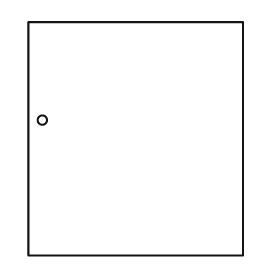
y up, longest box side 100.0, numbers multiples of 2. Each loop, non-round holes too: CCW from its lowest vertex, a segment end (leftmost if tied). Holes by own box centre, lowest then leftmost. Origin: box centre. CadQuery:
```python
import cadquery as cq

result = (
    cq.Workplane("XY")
    .moveTo(-46.0, -50.0)
    .lineTo(46.0, -50.0)
    .lineTo(46.0, 50.0)
    .lineTo(-46.0, 50.0)
    .close()
    .moveTo(-40.0, 8.0)
    .circle(2.0)
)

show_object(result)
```